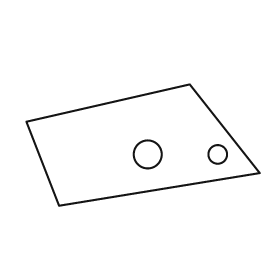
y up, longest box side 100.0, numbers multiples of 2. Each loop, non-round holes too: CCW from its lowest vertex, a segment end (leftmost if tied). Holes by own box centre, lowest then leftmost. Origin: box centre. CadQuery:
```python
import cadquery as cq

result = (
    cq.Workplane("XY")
    .moveTo(-36.0, -26.0)
    .lineTo(50.0, -12.0)
    .lineTo(20.0, 26.0)
    .lineTo(-50.0, 10.0)
    .close()
    .moveTo(2.0, -4.0)
    .circle(6.0)
    .moveTo(32.0, -4.0)
    .circle(4.0)
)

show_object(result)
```